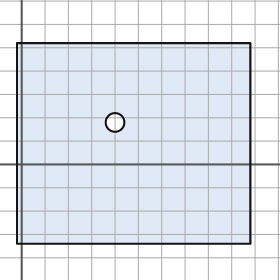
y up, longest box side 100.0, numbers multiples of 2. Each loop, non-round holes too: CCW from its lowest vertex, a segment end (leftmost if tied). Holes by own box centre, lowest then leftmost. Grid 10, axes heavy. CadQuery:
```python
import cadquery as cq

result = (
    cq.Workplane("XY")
    .moveTo(-2.0, -34.0)
    .lineTo(98.0, -34.0)
    .lineTo(98.0, 52.0)
    .lineTo(-2.0, 52.0)
    .close()
    .moveTo(40.0, 18.0)
    .circle(4.0)
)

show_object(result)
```